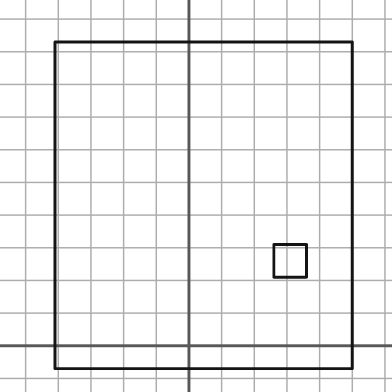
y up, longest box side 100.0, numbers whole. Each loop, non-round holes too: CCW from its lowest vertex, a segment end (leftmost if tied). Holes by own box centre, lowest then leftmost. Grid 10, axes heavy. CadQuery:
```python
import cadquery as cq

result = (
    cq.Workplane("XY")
    .moveTo(-41.0, -7.0)
    .lineTo(50.0, -7.0)
    .lineTo(50.0, 93.0)
    .lineTo(-41.0, 93.0)
    .close()
    .moveTo(26.0, 21.0)
    .lineTo(36.0, 21.0)
    .lineTo(36.0, 31.0)
    .lineTo(26.0, 31.0)
    .close()
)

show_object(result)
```